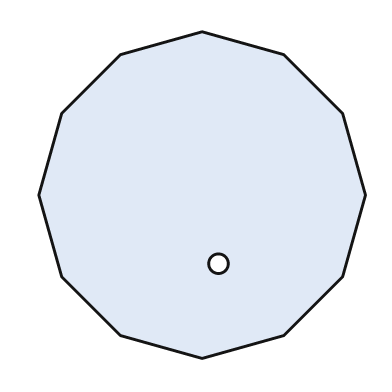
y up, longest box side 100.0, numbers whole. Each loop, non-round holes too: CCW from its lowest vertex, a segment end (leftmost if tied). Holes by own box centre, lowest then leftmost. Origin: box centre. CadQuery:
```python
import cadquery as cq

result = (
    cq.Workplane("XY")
    .moveTo(0.0, -50.0)
    .lineTo(25.0, -43.0)
    .lineTo(43.0, -25.0)
    .lineTo(50.0, 0.0)
    .lineTo(43.0, 25.0)
    .lineTo(25.0, 43.0)
    .lineTo(0.0, 50.0)
    .lineTo(-25.0, 43.0)
    .lineTo(-43.0, 25.0)
    .lineTo(-50.0, 0.0)
    .lineTo(-43.0, -25.0)
    .lineTo(-25.0, -43.0)
    .close()
    .moveTo(5.0, -21.0)
    .circle(3.0)
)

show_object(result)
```